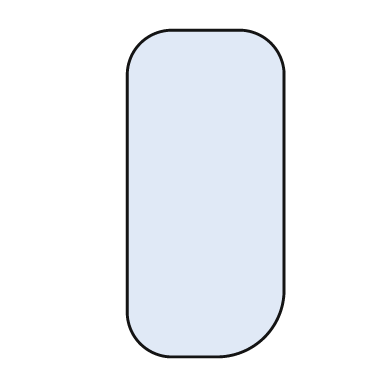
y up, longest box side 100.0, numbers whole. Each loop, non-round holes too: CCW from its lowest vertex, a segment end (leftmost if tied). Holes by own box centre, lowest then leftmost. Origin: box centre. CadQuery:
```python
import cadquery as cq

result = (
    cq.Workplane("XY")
    .moveTo(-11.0, -50.0)
    .lineTo(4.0, -50.0)
    .threePointArc((18.0, -44.0), (24.0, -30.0))
    .lineTo(24.0, 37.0)
    .threePointArc((20.0, 46.0), (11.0, 50.0))
    .lineTo(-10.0, 50.0)
    .threePointArc((-20.0, 46.0), (-24.0, 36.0))
    .lineTo(-24.0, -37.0)
    .threePointArc((-20.0, -46.0), (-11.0, -50.0))
    .close()
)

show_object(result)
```